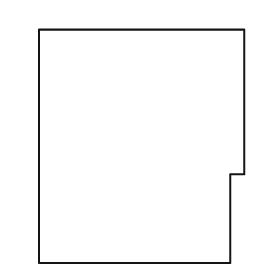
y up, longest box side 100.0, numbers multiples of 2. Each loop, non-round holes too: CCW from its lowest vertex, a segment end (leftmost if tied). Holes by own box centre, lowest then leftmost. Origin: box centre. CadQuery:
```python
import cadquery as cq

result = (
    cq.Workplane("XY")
    .moveTo(-44.0, -50.0)
    .lineTo(38.0, -50.0)
    .lineTo(38.0, -12.0)
    .lineTo(44.0, -12.0)
    .lineTo(44.0, 50.0)
    .lineTo(-44.0, 50.0)
    .close()
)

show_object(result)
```